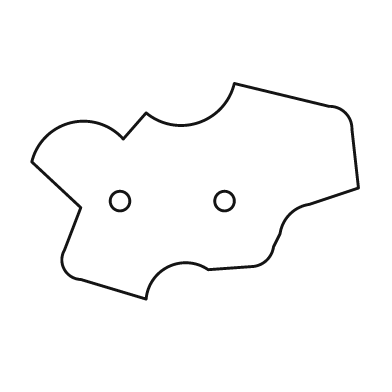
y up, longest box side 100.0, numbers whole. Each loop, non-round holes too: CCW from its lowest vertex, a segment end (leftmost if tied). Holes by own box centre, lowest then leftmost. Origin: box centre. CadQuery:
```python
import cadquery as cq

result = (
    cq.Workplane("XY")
    .moveTo(-15.0, -33.0)
    .threePointArc((-8.0, -23.0), (4.0, -24.0))
    .lineTo(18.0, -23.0)
    .threePointArc((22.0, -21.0), (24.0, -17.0))
    .lineTo(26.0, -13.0)
    .threePointArc((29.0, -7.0), (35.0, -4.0))
    .lineTo(50.0, 1.0)
    .lineTo(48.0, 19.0)
    .threePointArc((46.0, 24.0), (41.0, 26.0))
    .lineTo(12.0, 33.0)
    .threePointArc((1.0, 21.0), (-15.0, 24.0))
    .lineTo(-22.0, 16.0)
    .threePointArc((-38.0, 21.0), (-50.0, 9.0))
    .lineTo(-35.0, -5.0)
    .lineTo(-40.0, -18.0)
    .threePointArc((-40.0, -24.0), (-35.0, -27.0))
    .close()
    .moveTo(-23.0, -3.0)
    .circle(3.0)
    .moveTo(9.0, -3.0)
    .circle(3.0)
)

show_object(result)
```